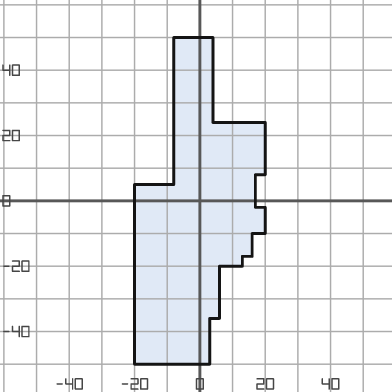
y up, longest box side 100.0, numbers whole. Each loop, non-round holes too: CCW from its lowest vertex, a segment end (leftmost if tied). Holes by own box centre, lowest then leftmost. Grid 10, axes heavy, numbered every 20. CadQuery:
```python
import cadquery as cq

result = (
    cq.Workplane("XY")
    .moveTo(-20.0, -50.0)
    .lineTo(3.0, -50.0)
    .lineTo(3.0, -36.0)
    .lineTo(6.0, -36.0)
    .lineTo(6.0, -20.0)
    .lineTo(13.0, -20.0)
    .lineTo(13.0, -17.0)
    .lineTo(16.0, -17.0)
    .lineTo(16.0, -10.0)
    .lineTo(20.0, -10.0)
    .lineTo(20.0, -2.0)
    .lineTo(17.0, -2.0)
    .lineTo(17.0, 8.0)
    .lineTo(20.0, 8.0)
    .lineTo(20.0, 24.0)
    .lineTo(4.0, 24.0)
    .lineTo(4.0, 50.0)
    .lineTo(-8.0, 50.0)
    .lineTo(-8.0, 5.0)
    .lineTo(-20.0, 5.0)
    .close()
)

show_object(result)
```